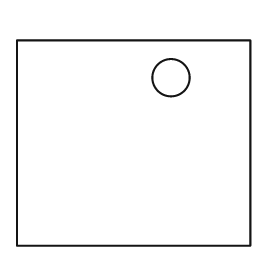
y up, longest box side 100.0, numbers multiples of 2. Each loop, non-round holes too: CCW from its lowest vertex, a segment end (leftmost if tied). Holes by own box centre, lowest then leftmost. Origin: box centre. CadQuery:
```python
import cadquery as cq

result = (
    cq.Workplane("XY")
    .moveTo(-50.0, -44.0)
    .lineTo(50.0, -44.0)
    .lineTo(50.0, 44.0)
    .lineTo(-50.0, 44.0)
    .close()
    .moveTo(16.0, 28.0)
    .circle(8.0)
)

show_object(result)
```